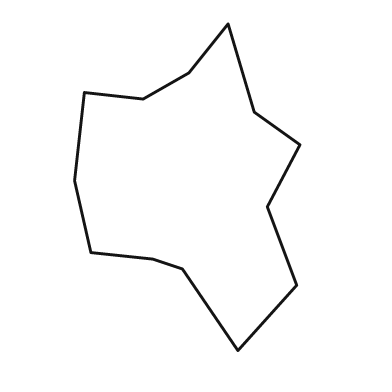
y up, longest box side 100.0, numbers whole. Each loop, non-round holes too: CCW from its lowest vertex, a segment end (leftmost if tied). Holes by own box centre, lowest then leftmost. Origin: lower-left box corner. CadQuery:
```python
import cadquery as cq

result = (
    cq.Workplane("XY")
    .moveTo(50.0, 0.0)
    .lineTo(68.0, 20.0)
    .lineTo(59.0, 44.0)
    .lineTo(69.0, 63.0)
    .lineTo(55.0, 73.0)
    .lineTo(47.0, 100.0)
    .lineTo(35.0, 85.0)
    .lineTo(21.0, 77.0)
    .lineTo(3.0, 79.0)
    .lineTo(0.0, 52.0)
    .lineTo(5.0, 30.0)
    .lineTo(24.0, 28.0)
    .lineTo(33.0, 25.0)
    .close()
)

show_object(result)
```